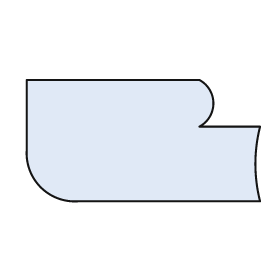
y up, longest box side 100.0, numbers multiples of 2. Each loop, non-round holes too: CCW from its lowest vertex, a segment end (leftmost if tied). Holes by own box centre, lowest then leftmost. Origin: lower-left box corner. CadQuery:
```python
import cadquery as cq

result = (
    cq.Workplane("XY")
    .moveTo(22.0, 0.0)
    .lineTo(100.0, 0.0)
    .threePointArc((98.0, 16.0), (100.0, 32.0))
    .lineTo(74.0, 32.0)
    .threePointArc((80.0, 42.0), (74.0, 52.0))
    .lineTo(0.0, 52.0)
    .lineTo(0.0, 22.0)
    .threePointArc((6.0, 6.0), (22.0, 0.0))
    .close()
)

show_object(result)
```